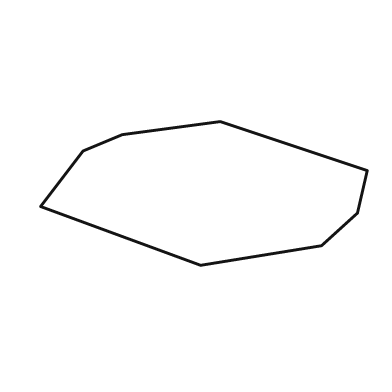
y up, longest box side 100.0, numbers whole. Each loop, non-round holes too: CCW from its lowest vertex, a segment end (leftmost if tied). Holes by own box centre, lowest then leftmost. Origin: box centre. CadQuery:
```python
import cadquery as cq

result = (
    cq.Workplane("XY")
    .moveTo(-1.0, -22.0)
    .lineTo(36.0, -16.0)
    .lineTo(47.0, -6.0)
    .lineTo(50.0, 7.0)
    .lineTo(5.0, 22.0)
    .lineTo(-25.0, 18.0)
    .lineTo(-37.0, 13.0)
    .lineTo(-50.0, -4.0)
    .close()
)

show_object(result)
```